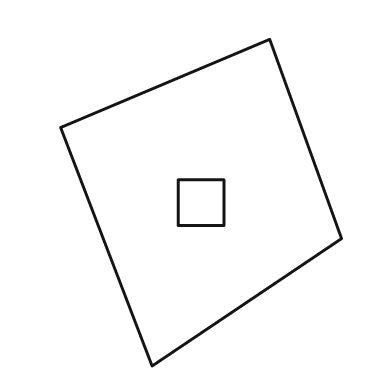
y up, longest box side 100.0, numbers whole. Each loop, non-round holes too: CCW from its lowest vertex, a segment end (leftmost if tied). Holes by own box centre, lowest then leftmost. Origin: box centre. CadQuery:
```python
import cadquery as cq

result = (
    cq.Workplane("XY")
    .moveTo(-15.0, -50.0)
    .lineTo(43.0, -11.0)
    .lineTo(21.0, 50.0)
    .lineTo(-43.0, 23.0)
    .close()
    .moveTo(-7.0, -7.0)
    .lineTo(7.0, -7.0)
    .lineTo(7.0, 7.0)
    .lineTo(-7.0, 7.0)
    .close()
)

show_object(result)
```